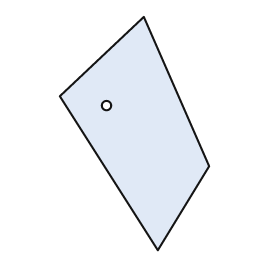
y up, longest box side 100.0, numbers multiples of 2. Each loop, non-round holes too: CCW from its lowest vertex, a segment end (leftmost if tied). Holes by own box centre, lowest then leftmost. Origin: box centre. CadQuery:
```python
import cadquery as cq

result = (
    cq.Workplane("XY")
    .moveTo(10.0, -50.0)
    .lineTo(32.0, -14.0)
    .lineTo(4.0, 50.0)
    .lineTo(-32.0, 16.0)
    .close()
    .moveTo(-12.0, 12.0)
    .circle(2.0)
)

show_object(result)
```